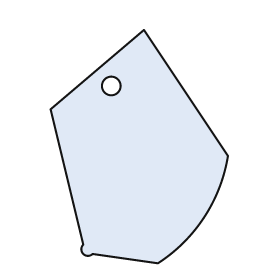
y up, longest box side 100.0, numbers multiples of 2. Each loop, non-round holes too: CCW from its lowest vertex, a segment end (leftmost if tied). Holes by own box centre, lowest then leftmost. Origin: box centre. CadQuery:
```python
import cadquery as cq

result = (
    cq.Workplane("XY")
    .moveTo(8.0, -50.0)
    .threePointArc((28.0, -30.0), (38.0, -4.0))
    .lineTo(2.0, 50.0)
    .lineTo(-38.0, 16.0)
    .lineTo(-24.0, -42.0)
    .threePointArc((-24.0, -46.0), (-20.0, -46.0))
    .close()
    .moveTo(-12.0, 26.0)
    .circle(4.0)
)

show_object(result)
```